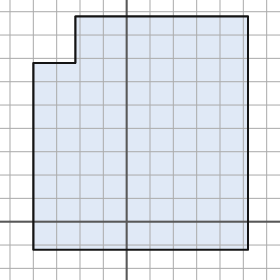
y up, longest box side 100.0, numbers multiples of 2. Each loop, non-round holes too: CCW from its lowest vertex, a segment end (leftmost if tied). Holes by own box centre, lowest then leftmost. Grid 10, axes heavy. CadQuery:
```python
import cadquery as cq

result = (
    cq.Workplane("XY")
    .moveTo(-40.0, -12.0)
    .lineTo(52.0, -12.0)
    .lineTo(52.0, 88.0)
    .lineTo(-22.0, 88.0)
    .lineTo(-22.0, 68.0)
    .lineTo(-40.0, 68.0)
    .close()
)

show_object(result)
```